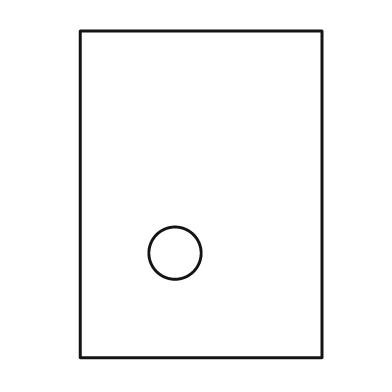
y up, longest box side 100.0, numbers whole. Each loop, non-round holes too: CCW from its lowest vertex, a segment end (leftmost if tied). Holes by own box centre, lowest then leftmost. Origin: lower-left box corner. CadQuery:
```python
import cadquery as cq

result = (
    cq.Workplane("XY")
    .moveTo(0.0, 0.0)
    .lineTo(74.0, 0.0)
    .lineTo(74.0, 100.0)
    .lineTo(0.0, 100.0)
    .close()
    .moveTo(29.0, 32.0)
    .circle(8.0)
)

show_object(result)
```